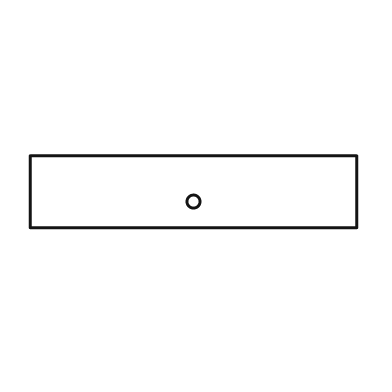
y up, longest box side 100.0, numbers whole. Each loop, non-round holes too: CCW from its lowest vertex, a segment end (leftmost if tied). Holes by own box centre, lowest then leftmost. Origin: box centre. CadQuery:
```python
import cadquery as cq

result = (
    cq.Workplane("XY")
    .moveTo(-50.0, -11.0)
    .lineTo(50.0, -11.0)
    .lineTo(50.0, 11.0)
    .lineTo(-50.0, 11.0)
    .close()
    .moveTo(0.0, -3.0)
    .circle(2.0)
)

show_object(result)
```